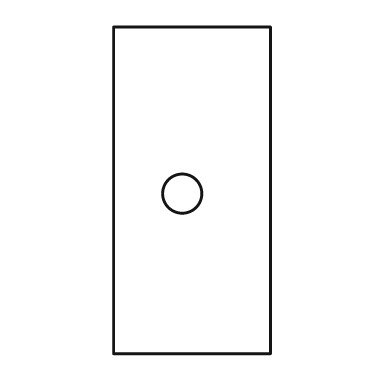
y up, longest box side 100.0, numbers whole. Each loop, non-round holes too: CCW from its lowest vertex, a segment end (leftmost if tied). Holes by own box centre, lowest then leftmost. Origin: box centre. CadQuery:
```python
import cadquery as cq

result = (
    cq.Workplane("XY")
    .moveTo(-24.0, -50.0)
    .lineTo(24.0, -50.0)
    .lineTo(24.0, 50.0)
    .lineTo(-24.0, 50.0)
    .close()
    .moveTo(-3.0, -1.0)
    .circle(6.0)
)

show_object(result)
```